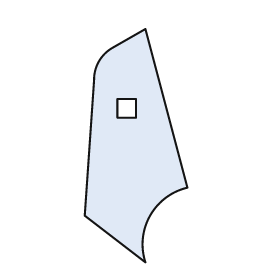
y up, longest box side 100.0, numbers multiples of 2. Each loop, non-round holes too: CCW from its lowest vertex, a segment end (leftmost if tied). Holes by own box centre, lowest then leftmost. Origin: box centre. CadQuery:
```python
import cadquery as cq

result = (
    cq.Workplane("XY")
    .moveTo(4.0, -50.0)
    .threePointArc((6.0, -30.0), (22.0, -18.0))
    .lineTo(4.0, 50.0)
    .lineTo(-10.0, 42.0)
    .threePointArc((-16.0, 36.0), (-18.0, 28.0))
    .lineTo(-22.0, -30.0)
    .close()
    .moveTo(-8.0, 12.0)
    .lineTo(0.0, 12.0)
    .lineTo(0.0, 20.0)
    .lineTo(-8.0, 20.0)
    .close()
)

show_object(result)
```